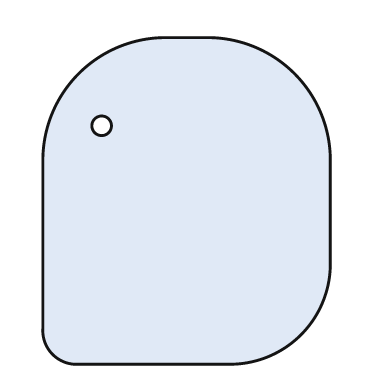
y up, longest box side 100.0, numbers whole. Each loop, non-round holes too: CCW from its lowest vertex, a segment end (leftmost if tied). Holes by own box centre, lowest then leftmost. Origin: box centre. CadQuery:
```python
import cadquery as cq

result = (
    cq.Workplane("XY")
    .moveTo(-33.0, -50.0)
    .lineTo(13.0, -50.0)
    .threePointArc((35.0, -41.0), (44.0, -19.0))
    .lineTo(44.0, 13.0)
    .threePointArc((33.0, 39.0), (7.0, 50.0))
    .lineTo(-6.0, 50.0)
    .threePointArc((-33.0, 39.0), (-44.0, 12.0))
    .lineTo(-44.0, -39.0)
    .threePointArc((-41.0, -47.0), (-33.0, -50.0))
    .close()
    .moveTo(-26.0, 23.0)
    .circle(3.0)
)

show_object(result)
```